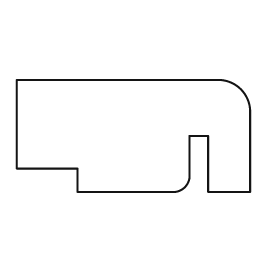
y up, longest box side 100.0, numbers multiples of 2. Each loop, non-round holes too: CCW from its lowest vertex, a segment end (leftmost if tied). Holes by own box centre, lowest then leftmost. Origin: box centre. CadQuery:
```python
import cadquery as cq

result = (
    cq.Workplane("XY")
    .moveTo(-24.0, -24.0)
    .lineTo(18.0, -24.0)
    .threePointArc((22.0, -22.0), (24.0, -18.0))
    .lineTo(24.0, 0.0)
    .lineTo(32.0, 0.0)
    .lineTo(32.0, -24.0)
    .lineTo(50.0, -24.0)
    .lineTo(50.0, 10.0)
    .threePointArc((46.0, 20.0), (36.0, 24.0))
    .lineTo(-50.0, 24.0)
    .lineTo(-50.0, -14.0)
    .lineTo(-24.0, -14.0)
    .close()
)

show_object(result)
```